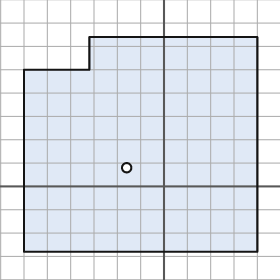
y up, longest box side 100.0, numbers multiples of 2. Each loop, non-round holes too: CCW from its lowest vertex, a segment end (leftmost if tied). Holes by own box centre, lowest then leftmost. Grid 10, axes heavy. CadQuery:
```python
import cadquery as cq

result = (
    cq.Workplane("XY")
    .moveTo(-60.0, -28.0)
    .lineTo(40.0, -28.0)
    .lineTo(40.0, 64.0)
    .lineTo(-32.0, 64.0)
    .lineTo(-32.0, 50.0)
    .lineTo(-60.0, 50.0)
    .close()
    .moveTo(-16.0, 8.0)
    .circle(2.0)
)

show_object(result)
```